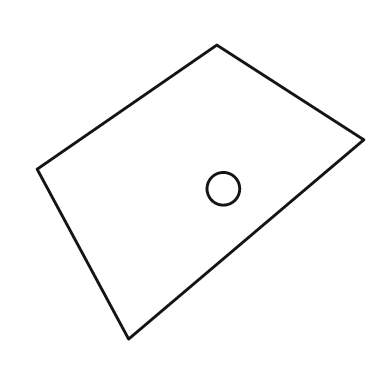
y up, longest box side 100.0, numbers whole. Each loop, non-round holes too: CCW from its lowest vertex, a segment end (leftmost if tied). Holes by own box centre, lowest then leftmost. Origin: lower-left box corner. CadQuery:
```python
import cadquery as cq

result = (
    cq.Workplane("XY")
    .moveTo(28.0, 0.0)
    .lineTo(100.0, 61.0)
    .lineTo(55.0, 90.0)
    .lineTo(0.0, 52.0)
    .close()
    .moveTo(57.0, 46.0)
    .circle(5.0)
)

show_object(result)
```